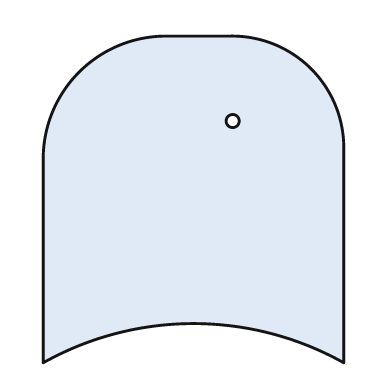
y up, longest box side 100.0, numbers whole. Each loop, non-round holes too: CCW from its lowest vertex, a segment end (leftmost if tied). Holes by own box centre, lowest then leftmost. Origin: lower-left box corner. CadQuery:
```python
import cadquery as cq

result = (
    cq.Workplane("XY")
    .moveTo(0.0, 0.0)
    .threePointArc((46.0, 12.0), (92.0, 0.0))
    .lineTo(92.0, 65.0)
    .threePointArc((82.0, 90.0), (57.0, 100.0))
    .lineTo(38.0, 100.0)
    .threePointArc((11.0, 89.0), (0.0, 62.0))
    .close()
    .moveTo(58.0, 74.0)
    .circle(2.0)
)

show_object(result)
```